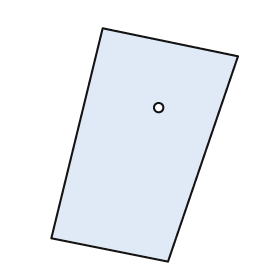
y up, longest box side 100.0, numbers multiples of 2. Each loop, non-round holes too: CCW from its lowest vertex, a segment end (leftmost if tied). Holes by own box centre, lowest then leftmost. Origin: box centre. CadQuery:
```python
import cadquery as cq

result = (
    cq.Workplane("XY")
    .moveTo(10.0, -50.0)
    .lineTo(40.0, 38.0)
    .lineTo(-18.0, 50.0)
    .lineTo(-40.0, -40.0)
    .close()
    .moveTo(6.0, 16.0)
    .circle(2.0)
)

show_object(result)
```